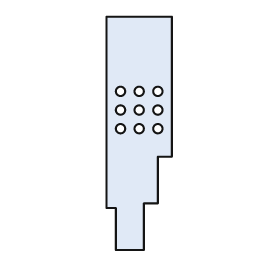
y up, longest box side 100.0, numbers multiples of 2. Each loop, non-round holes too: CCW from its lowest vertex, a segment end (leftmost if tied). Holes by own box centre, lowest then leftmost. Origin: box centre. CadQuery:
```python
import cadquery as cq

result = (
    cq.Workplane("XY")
    .moveTo(-10.0, -50.0)
    .lineTo(2.0, -50.0)
    .lineTo(2.0, -30.0)
    .lineTo(8.0, -30.0)
    .lineTo(8.0, -10.0)
    .lineTo(14.0, -10.0)
    .lineTo(14.0, 50.0)
    .lineTo(-14.0, 50.0)
    .lineTo(-14.0, -32.0)
    .lineTo(-10.0, -32.0)
    .close()
    .moveTo(-8.0, 2.0)
    .circle(2.0)
    .moveTo(0.0, 2.0)
    .circle(2.0)
    .moveTo(8.0, 2.0)
    .circle(2.0)
    .moveTo(-8.0, 10.0)
    .circle(2.0)
    .moveTo(0.0, 10.0)
    .circle(2.0)
    .moveTo(8.0, 10.0)
    .circle(2.0)
    .moveTo(-8.0, 18.0)
    .circle(2.0)
    .moveTo(0.0, 18.0)
    .circle(2.0)
    .moveTo(8.0, 18.0)
    .circle(2.0)
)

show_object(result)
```